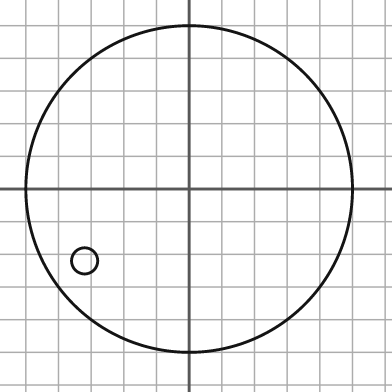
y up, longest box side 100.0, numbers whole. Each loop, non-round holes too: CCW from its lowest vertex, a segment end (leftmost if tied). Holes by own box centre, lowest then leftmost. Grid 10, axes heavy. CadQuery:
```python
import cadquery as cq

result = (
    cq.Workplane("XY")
    .moveTo(0.0, 0.0)
    .circle(50.0)
    .moveTo(-32.0, -22.0)
    .circle(4.0)
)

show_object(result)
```